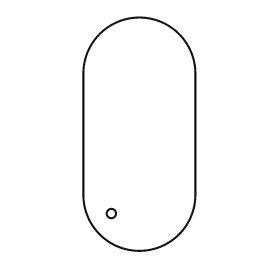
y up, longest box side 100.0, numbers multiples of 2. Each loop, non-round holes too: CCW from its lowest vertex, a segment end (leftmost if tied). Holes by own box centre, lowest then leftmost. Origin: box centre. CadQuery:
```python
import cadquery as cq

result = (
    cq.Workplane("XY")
    .moveTo(-24.0, -26.0)
    .threePointArc((0.0, -50.0), (24.0, -26.0))
    .lineTo(24.0, 26.0)
    .threePointArc((0.0, 50.0), (-24.0, 26.0))
    .close()
    .moveTo(-12.0, -34.0)
    .circle(2.0)
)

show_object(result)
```